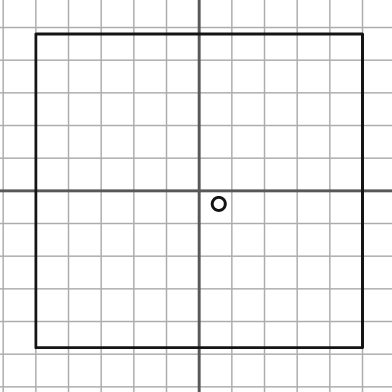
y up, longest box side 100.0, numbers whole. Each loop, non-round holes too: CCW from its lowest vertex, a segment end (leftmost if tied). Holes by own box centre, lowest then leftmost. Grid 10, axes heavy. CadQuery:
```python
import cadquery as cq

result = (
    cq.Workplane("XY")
    .moveTo(-50.0, -48.0)
    .lineTo(50.0, -48.0)
    .lineTo(50.0, 48.0)
    .lineTo(-50.0, 48.0)
    .close()
    .moveTo(6.0, -4.0)
    .circle(2.0)
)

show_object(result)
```